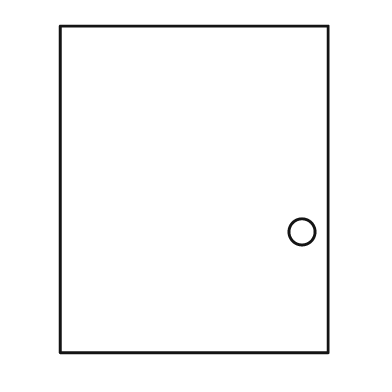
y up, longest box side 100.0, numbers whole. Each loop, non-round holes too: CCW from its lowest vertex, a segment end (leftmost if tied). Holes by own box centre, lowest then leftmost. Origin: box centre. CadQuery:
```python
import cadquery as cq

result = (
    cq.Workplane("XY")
    .moveTo(-41.0, -50.0)
    .lineTo(41.0, -50.0)
    .lineTo(41.0, 50.0)
    .lineTo(-41.0, 50.0)
    .close()
    .moveTo(33.0, -13.0)
    .circle(4.0)
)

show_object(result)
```